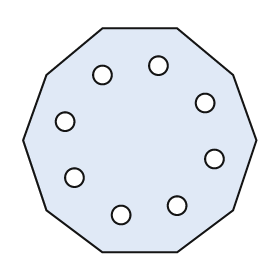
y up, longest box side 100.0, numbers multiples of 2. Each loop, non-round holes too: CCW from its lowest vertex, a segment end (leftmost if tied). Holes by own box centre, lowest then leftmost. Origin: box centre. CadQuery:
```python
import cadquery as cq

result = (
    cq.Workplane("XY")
    .moveTo(-16.0, -48.0)
    .lineTo(16.0, -48.0)
    .lineTo(40.0, -30.0)
    .lineTo(50.0, 0.0)
    .lineTo(40.0, 28.0)
    .lineTo(16.0, 48.0)
    .lineTo(-16.0, 48.0)
    .lineTo(-40.0, 28.0)
    .lineTo(-50.0, 0.0)
    .lineTo(-40.0, -30.0)
    .close()
    .moveTo(-8.0, -32.0)
    .circle(4.0)
    .moveTo(16.0, -28.0)
    .circle(4.0)
    .moveTo(-28.0, -16.0)
    .circle(4.0)
    .moveTo(32.0, -8.0)
    .circle(4.0)
    .moveTo(-32.0, 8.0)
    .circle(4.0)
    .moveTo(28.0, 16.0)
    .circle(4.0)
    .moveTo(-16.0, 28.0)
    .circle(4.0)
    .moveTo(8.0, 32.0)
    .circle(4.0)
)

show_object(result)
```